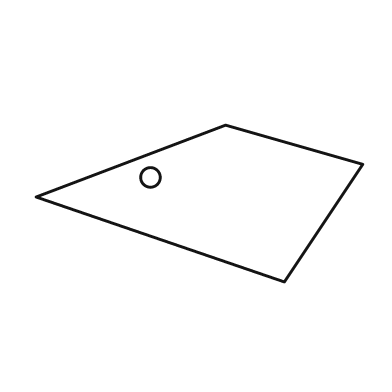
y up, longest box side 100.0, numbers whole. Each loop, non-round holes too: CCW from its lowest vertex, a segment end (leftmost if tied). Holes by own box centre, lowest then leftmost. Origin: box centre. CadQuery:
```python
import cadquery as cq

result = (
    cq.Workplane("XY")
    .moveTo(26.0, -24.0)
    .lineTo(50.0, 12.0)
    .lineTo(8.0, 24.0)
    .lineTo(-50.0, 2.0)
    .close()
    .moveTo(-15.0, 8.0)
    .circle(3.0)
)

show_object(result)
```